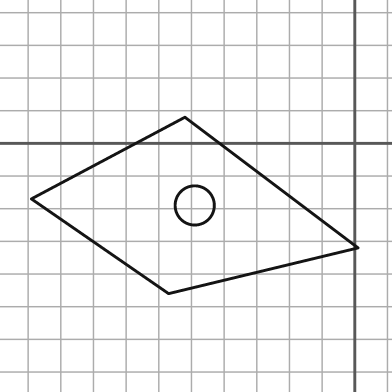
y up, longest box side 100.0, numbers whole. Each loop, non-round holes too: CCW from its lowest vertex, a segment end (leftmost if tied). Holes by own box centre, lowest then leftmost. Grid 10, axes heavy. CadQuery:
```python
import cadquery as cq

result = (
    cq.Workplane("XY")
    .moveTo(-57.0, -46.0)
    .lineTo(1.0, -32.0)
    .lineTo(-52.0, 8.0)
    .lineTo(-99.0, -17.0)
    .close()
    .moveTo(-49.0, -19.0)
    .circle(6.0)
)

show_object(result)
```